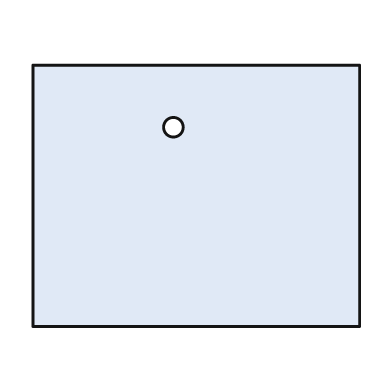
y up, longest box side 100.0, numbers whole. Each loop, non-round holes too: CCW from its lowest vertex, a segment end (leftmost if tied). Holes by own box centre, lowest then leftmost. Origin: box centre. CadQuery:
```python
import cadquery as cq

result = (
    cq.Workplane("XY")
    .moveTo(-50.0, -40.0)
    .lineTo(50.0, -40.0)
    .lineTo(50.0, 40.0)
    .lineTo(-50.0, 40.0)
    .close()
    .moveTo(-7.0, 21.0)
    .circle(3.0)
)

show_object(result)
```